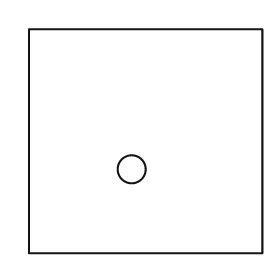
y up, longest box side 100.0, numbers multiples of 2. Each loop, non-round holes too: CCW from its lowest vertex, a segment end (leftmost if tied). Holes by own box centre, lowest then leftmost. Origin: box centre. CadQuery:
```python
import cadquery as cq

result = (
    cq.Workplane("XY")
    .moveTo(-50.0, -48.0)
    .lineTo(50.0, -48.0)
    .lineTo(50.0, 48.0)
    .lineTo(-50.0, 48.0)
    .close()
    .moveTo(-6.0, -12.0)
    .circle(6.0)
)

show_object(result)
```